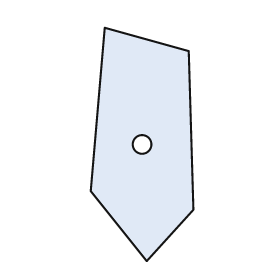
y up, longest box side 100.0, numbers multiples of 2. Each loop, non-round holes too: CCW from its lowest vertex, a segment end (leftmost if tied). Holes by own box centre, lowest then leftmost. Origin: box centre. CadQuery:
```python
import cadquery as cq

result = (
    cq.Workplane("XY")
    .moveTo(2.0, -50.0)
    .lineTo(22.0, -28.0)
    .lineTo(20.0, 40.0)
    .lineTo(-16.0, 50.0)
    .lineTo(-22.0, -20.0)
    .close()
    .moveTo(0.0, 0.0)
    .circle(4.0)
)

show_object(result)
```